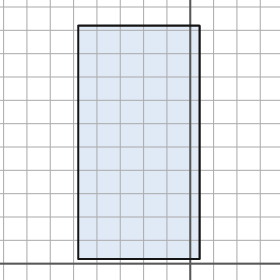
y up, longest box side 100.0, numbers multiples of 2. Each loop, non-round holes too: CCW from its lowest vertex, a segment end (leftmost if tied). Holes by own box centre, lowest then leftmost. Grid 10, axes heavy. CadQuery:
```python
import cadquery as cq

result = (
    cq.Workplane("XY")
    .moveTo(-48.0, 2.0)
    .lineTo(4.0, 2.0)
    .lineTo(4.0, 102.0)
    .lineTo(-48.0, 102.0)
    .close()
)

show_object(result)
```